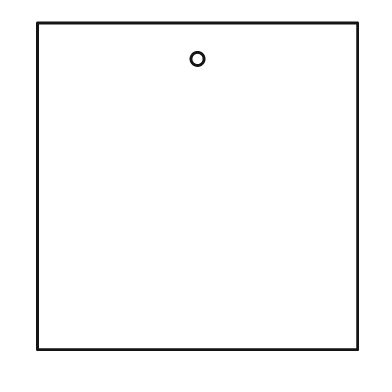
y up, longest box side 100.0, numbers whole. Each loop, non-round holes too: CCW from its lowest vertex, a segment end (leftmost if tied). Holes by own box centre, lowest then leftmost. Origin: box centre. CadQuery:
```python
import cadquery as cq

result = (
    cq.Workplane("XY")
    .moveTo(-49.0, -50.0)
    .lineTo(49.0, -50.0)
    .lineTo(49.0, 50.0)
    .lineTo(-49.0, 50.0)
    .close()
    .moveTo(0.0, 39.0)
    .circle(2.0)
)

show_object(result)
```